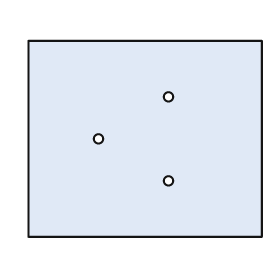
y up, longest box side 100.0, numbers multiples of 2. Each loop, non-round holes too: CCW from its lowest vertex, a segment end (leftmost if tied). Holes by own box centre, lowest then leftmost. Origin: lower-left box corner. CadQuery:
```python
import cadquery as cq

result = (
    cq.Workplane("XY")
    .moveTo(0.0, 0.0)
    .lineTo(100.0, 0.0)
    .lineTo(100.0, 84.0)
    .lineTo(0.0, 84.0)
    .close()
    .moveTo(60.0, 24.0)
    .circle(2.0)
    .moveTo(30.0, 42.0)
    .circle(2.0)
    .moveTo(60.0, 60.0)
    .circle(2.0)
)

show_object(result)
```